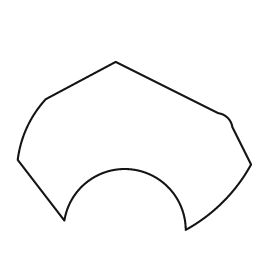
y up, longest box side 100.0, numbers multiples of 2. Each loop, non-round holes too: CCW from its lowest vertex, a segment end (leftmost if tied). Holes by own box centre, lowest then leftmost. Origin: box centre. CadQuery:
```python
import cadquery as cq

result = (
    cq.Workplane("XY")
    .moveTo(22.0, -36.0)
    .threePointArc((38.0, -24.0), (50.0, -8.0))
    .lineTo(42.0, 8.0)
    .threePointArc((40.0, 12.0), (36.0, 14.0))
    .lineTo(-8.0, 36.0)
    .lineTo(-38.0, 20.0)
    .threePointArc((-46.0, 8.0), (-50.0, -6.0))
    .lineTo(-30.0, -32.0)
    .threePointArc((-2.0, -10.0), (22.0, -36.0))
    .close()
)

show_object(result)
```